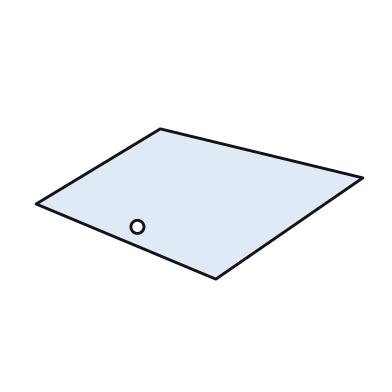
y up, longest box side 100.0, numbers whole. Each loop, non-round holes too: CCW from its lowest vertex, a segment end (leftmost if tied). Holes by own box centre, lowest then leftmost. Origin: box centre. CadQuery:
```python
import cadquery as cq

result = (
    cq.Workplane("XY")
    .moveTo(5.0, -23.0)
    .lineTo(50.0, 8.0)
    .lineTo(-12.0, 23.0)
    .lineTo(-50.0, 0.0)
    .close()
    .moveTo(-19.0, -7.0)
    .circle(2.0)
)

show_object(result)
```